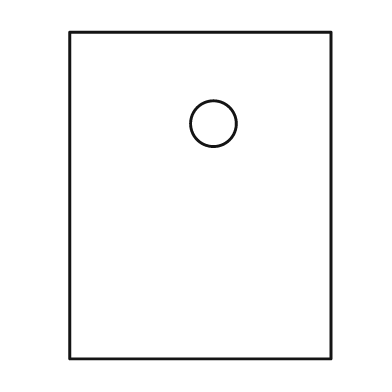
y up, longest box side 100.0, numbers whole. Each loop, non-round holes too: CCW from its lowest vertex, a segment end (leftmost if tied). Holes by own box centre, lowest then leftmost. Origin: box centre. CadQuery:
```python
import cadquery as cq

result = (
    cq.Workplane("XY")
    .moveTo(-40.0, -50.0)
    .lineTo(40.0, -50.0)
    .lineTo(40.0, 50.0)
    .lineTo(-40.0, 50.0)
    .close()
    .moveTo(4.0, 22.0)
    .circle(7.0)
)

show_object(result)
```